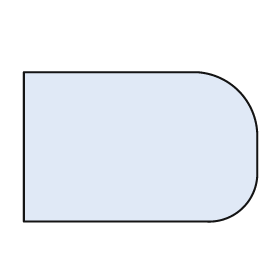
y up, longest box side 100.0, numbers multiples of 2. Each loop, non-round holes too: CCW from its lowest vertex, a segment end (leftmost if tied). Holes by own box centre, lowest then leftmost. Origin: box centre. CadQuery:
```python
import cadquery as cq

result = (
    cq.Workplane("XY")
    .moveTo(-50.0, -32.0)
    .lineTo(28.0, -32.0)
    .threePointArc((44.0, -26.0), (50.0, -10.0))
    .lineTo(50.0, 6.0)
    .threePointArc((42.0, 24.0), (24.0, 32.0))
    .lineTo(-50.0, 32.0)
    .close()
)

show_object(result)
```